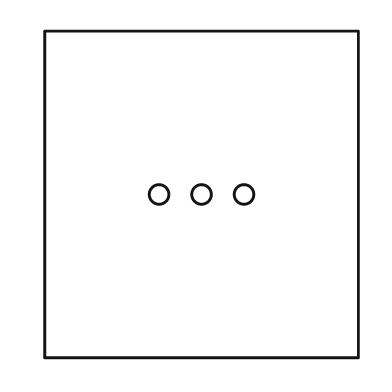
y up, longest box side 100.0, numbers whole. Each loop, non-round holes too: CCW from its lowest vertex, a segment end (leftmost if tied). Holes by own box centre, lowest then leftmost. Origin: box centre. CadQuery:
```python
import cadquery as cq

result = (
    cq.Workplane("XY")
    .moveTo(-48.0, -50.0)
    .lineTo(48.0, -50.0)
    .lineTo(48.0, 50.0)
    .lineTo(-48.0, 50.0)
    .close()
    .moveTo(-13.0, 0.0)
    .circle(3.0)
    .moveTo(0.0, 0.0)
    .circle(3.0)
    .moveTo(13.0, 0.0)
    .circle(3.0)
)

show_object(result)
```